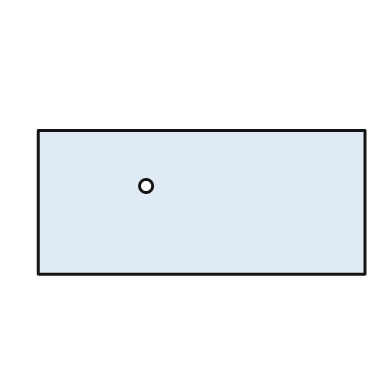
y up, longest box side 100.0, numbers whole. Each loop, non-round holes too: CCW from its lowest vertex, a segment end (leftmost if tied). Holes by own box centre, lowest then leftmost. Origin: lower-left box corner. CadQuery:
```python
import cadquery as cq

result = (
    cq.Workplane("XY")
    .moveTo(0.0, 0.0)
    .lineTo(100.0, 0.0)
    .lineTo(100.0, 44.0)
    .lineTo(0.0, 44.0)
    .close()
    .moveTo(33.0, 27.0)
    .circle(2.0)
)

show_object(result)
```